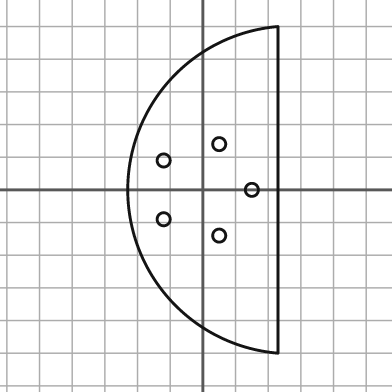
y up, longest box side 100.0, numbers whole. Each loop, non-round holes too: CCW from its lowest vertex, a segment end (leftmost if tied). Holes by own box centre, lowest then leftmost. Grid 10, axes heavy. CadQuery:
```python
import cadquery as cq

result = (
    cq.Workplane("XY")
    .moveTo(23.0, -50.0)
    .lineTo(23.0, 50.0)
    .threePointArc((-23.0, 0.0), (23.0, -50.0))
    .close()
    .moveTo(5.0, -14.0)
    .circle(2.0)
    .moveTo(-12.0, -9.0)
    .circle(2.0)
    .moveTo(15.0, 0.0)
    .circle(2.0)
    .moveTo(-12.0, 9.0)
    .circle(2.0)
    .moveTo(5.0, 14.0)
    .circle(2.0)
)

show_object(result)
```